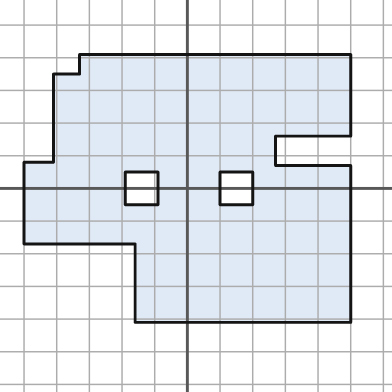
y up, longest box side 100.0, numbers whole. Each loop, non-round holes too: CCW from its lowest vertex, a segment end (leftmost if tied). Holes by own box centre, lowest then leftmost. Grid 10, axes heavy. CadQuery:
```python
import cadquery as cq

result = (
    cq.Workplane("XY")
    .moveTo(-16.0, -41.0)
    .lineTo(50.0, -41.0)
    .lineTo(50.0, 7.0)
    .lineTo(27.0, 7.0)
    .lineTo(27.0, 16.0)
    .lineTo(50.0, 16.0)
    .lineTo(50.0, 41.0)
    .lineTo(-33.0, 41.0)
    .lineTo(-33.0, 35.0)
    .lineTo(-41.0, 35.0)
    .lineTo(-41.0, 8.0)
    .lineTo(-50.0, 8.0)
    .lineTo(-50.0, -17.0)
    .lineTo(-16.0, -17.0)
    .close()
    .moveTo(-19.0, -5.0)
    .lineTo(-9.0, -5.0)
    .lineTo(-9.0, 5.0)
    .lineTo(-19.0, 5.0)
    .close()
    .moveTo(10.0, -5.0)
    .lineTo(20.0, -5.0)
    .lineTo(20.0, 5.0)
    .lineTo(10.0, 5.0)
    .close()
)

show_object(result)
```